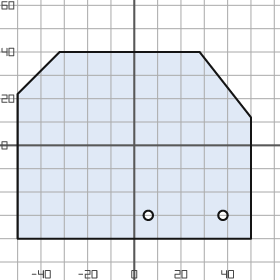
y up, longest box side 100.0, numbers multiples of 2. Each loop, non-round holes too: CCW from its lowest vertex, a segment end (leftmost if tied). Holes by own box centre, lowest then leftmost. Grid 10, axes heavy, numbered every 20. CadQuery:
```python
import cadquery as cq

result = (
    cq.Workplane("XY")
    .moveTo(-50.0, -40.0)
    .lineTo(50.0, -40.0)
    .lineTo(50.0, 12.0)
    .lineTo(28.0, 40.0)
    .lineTo(-32.0, 40.0)
    .lineTo(-50.0, 22.0)
    .close()
    .moveTo(6.0, -30.0)
    .circle(2.0)
    .moveTo(38.0, -30.0)
    .circle(2.0)
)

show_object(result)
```